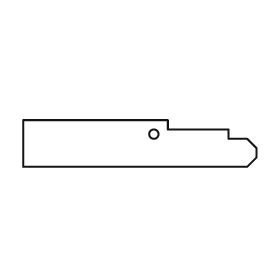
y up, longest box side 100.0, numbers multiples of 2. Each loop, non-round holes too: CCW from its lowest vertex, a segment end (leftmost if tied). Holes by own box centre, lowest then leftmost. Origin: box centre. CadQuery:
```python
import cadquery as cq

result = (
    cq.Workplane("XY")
    .moveTo(-50.0, -10.0)
    .lineTo(46.0, -10.0)
    .lineTo(50.0, -6.0)
    .lineTo(50.0, -2.0)
    .lineTo(46.0, 2.0)
    .lineTo(38.0, 2.0)
    .lineTo(38.0, 6.0)
    .lineTo(12.0, 6.0)
    .lineTo(12.0, 10.0)
    .lineTo(-50.0, 10.0)
    .close()
    .moveTo(6.0, 4.0)
    .circle(2.0)
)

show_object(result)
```